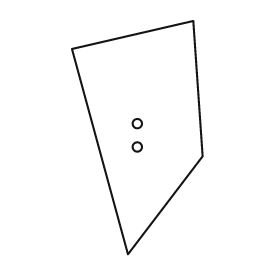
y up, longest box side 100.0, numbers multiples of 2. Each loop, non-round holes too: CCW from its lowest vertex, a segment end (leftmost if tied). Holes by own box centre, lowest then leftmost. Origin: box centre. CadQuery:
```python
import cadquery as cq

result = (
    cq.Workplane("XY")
    .moveTo(-4.0, -50.0)
    .lineTo(28.0, -8.0)
    .lineTo(24.0, 50.0)
    .lineTo(-28.0, 38.0)
    .close()
    .moveTo(0.0, -4.0)
    .circle(2.0)
    .moveTo(0.0, 6.0)
    .circle(2.0)
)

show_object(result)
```